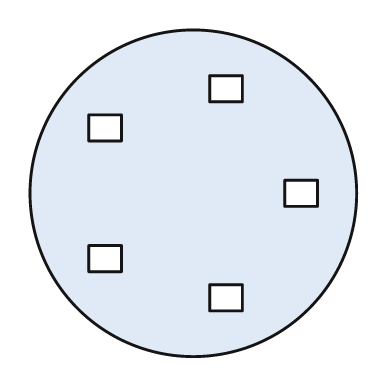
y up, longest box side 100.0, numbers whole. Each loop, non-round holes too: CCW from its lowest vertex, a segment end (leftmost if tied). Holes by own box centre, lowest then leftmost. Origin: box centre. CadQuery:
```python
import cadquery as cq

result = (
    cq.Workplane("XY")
    .moveTo(0.0, 0.0)
    .circle(50.0)
    .moveTo(5.0, -36.0)
    .lineTo(15.0, -36.0)
    .lineTo(15.0, -28.0)
    .lineTo(5.0, -28.0)
    .close()
    .moveTo(-32.0, -24.0)
    .lineTo(-22.0, -24.0)
    .lineTo(-22.0, -16.0)
    .lineTo(-32.0, -16.0)
    .close()
    .moveTo(28.0, -4.0)
    .lineTo(38.0, -4.0)
    .lineTo(38.0, 4.0)
    .lineTo(28.0, 4.0)
    .close()
    .moveTo(-32.0, 16.0)
    .lineTo(-22.0, 16.0)
    .lineTo(-22.0, 24.0)
    .lineTo(-32.0, 24.0)
    .close()
    .moveTo(5.0, 28.0)
    .lineTo(15.0, 28.0)
    .lineTo(15.0, 36.0)
    .lineTo(5.0, 36.0)
    .close()
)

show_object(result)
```